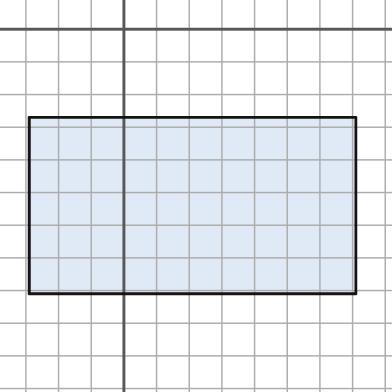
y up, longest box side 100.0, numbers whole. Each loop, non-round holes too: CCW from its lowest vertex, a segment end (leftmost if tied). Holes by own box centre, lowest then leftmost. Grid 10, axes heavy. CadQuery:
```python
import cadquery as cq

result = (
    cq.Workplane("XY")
    .moveTo(-29.0, -81.0)
    .lineTo(71.0, -81.0)
    .lineTo(71.0, -27.0)
    .lineTo(-29.0, -27.0)
    .close()
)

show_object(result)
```